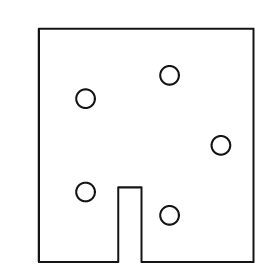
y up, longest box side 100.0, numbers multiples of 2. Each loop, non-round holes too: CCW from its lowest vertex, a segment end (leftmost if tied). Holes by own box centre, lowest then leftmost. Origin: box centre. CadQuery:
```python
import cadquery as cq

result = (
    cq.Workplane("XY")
    .moveTo(-46.0, -50.0)
    .lineTo(-12.0, -50.0)
    .lineTo(-12.0, -18.0)
    .lineTo(-2.0, -18.0)
    .lineTo(-2.0, -50.0)
    .lineTo(46.0, -50.0)
    .lineTo(46.0, 50.0)
    .lineTo(-46.0, 50.0)
    .close()
    .moveTo(10.0, -30.0)
    .circle(4.0)
    .moveTo(-26.0, -20.0)
    .circle(4.0)
    .moveTo(32.0, 0.0)
    .circle(4.0)
    .moveTo(-26.0, 20.0)
    .circle(4.0)
    .moveTo(10.0, 30.0)
    .circle(4.0)
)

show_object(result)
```